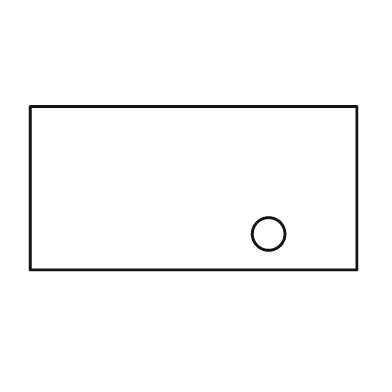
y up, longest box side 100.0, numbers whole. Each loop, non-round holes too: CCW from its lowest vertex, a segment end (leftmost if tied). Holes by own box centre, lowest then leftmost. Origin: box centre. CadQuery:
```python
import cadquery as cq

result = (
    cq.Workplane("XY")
    .moveTo(-50.0, -25.0)
    .lineTo(50.0, -25.0)
    .lineTo(50.0, 25.0)
    .lineTo(-50.0, 25.0)
    .close()
    .moveTo(23.0, -14.0)
    .circle(5.0)
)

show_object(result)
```